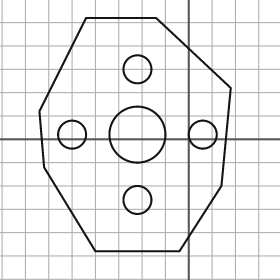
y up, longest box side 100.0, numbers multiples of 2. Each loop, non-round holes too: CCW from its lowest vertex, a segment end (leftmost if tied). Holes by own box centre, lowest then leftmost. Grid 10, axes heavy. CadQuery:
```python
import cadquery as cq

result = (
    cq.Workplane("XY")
    .moveTo(-40.0, -48.0)
    .lineTo(-4.0, -48.0)
    .lineTo(14.0, -20.0)
    .lineTo(18.0, 22.0)
    .lineTo(-14.0, 52.0)
    .lineTo(-44.0, 52.0)
    .lineTo(-64.0, 12.0)
    .lineTo(-62.0, -12.0)
    .close()
    .moveTo(-22.0, -26.0)
    .circle(6.0)
    .moveTo(-50.0, 2.0)
    .circle(6.0)
    .moveTo(-22.0, 2.0)
    .circle(12.0)
    .moveTo(6.0, 2.0)
    .circle(6.0)
    .moveTo(-22.0, 30.0)
    .circle(6.0)
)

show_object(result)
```